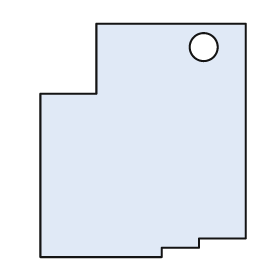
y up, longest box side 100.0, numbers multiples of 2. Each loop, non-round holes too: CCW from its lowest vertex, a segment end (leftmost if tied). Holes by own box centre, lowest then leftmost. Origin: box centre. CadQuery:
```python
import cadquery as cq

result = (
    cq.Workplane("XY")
    .moveTo(-44.0, -50.0)
    .lineTo(8.0, -50.0)
    .lineTo(8.0, -46.0)
    .lineTo(24.0, -46.0)
    .lineTo(24.0, -42.0)
    .lineTo(44.0, -42.0)
    .lineTo(44.0, 50.0)
    .lineTo(-20.0, 50.0)
    .lineTo(-20.0, 20.0)
    .lineTo(-44.0, 20.0)
    .close()
    .moveTo(26.0, 40.0)
    .circle(6.0)
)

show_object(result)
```